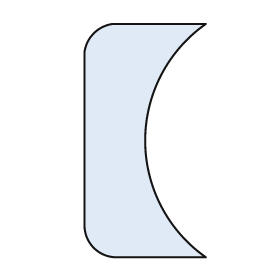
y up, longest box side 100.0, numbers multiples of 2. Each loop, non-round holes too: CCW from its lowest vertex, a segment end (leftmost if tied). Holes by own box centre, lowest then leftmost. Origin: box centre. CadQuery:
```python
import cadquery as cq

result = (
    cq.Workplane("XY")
    .moveTo(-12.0, -50.0)
    .lineTo(26.0, -50.0)
    .threePointArc((0.0, 0.0), (26.0, 50.0))
    .lineTo(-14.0, 50.0)
    .threePointArc((-22.0, 46.0), (-26.0, 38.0))
    .lineTo(-26.0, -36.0)
    .threePointArc((-22.0, -46.0), (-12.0, -50.0))
    .close()
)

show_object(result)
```